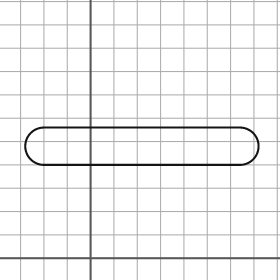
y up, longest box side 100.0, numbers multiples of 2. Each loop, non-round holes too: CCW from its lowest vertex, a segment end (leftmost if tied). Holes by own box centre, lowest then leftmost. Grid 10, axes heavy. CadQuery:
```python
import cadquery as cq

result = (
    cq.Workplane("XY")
    .moveTo(-20.0, 40.0)
    .lineTo(64.0, 40.0)
    .threePointArc((72.0, 48.0), (64.0, 56.0))
    .lineTo(-20.0, 56.0)
    .threePointArc((-28.0, 48.0), (-20.0, 40.0))
    .close()
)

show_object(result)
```